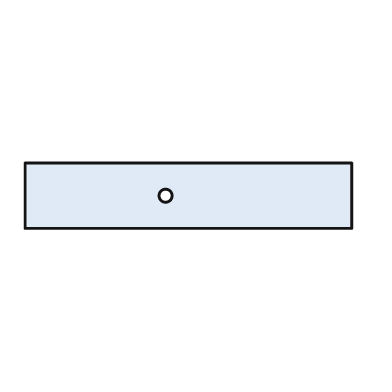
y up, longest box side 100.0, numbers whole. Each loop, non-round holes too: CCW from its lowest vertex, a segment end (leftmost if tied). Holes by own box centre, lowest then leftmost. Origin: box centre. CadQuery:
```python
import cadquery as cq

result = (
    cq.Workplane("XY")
    .moveTo(-50.0, -10.0)
    .lineTo(50.0, -10.0)
    .lineTo(50.0, 10.0)
    .lineTo(-50.0, 10.0)
    .close()
    .moveTo(-7.0, 0.0)
    .circle(2.0)
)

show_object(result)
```